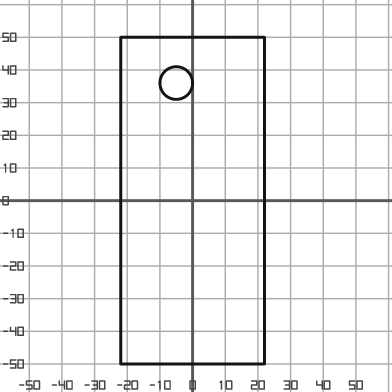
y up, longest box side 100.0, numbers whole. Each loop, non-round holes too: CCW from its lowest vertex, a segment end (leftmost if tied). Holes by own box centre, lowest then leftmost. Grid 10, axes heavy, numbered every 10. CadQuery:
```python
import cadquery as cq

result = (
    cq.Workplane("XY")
    .moveTo(-22.0, -50.0)
    .lineTo(22.0, -50.0)
    .lineTo(22.0, 50.0)
    .lineTo(-22.0, 50.0)
    .close()
    .moveTo(-5.0, 36.0)
    .circle(5.0)
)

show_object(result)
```